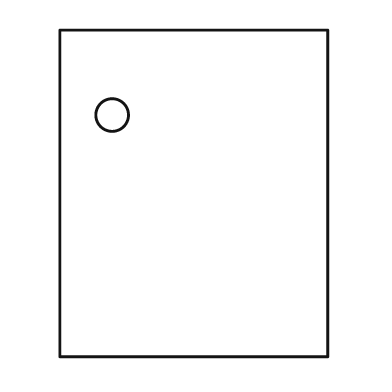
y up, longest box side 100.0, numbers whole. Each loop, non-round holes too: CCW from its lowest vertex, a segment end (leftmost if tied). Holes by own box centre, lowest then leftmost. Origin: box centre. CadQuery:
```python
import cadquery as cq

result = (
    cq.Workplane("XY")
    .moveTo(-41.0, -50.0)
    .lineTo(41.0, -50.0)
    .lineTo(41.0, 50.0)
    .lineTo(-41.0, 50.0)
    .close()
    .moveTo(-25.0, 24.0)
    .circle(5.0)
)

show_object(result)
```